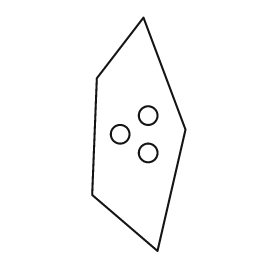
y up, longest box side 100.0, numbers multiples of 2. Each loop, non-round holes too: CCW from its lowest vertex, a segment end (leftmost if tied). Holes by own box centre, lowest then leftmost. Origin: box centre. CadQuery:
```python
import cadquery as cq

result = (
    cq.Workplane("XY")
    .moveTo(8.0, -50.0)
    .lineTo(20.0, 2.0)
    .lineTo(2.0, 50.0)
    .lineTo(-18.0, 24.0)
    .lineTo(-20.0, -26.0)
    .close()
    .moveTo(4.0, -8.0)
    .circle(4.0)
    .moveTo(-8.0, 0.0)
    .circle(4.0)
    .moveTo(4.0, 8.0)
    .circle(4.0)
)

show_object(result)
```